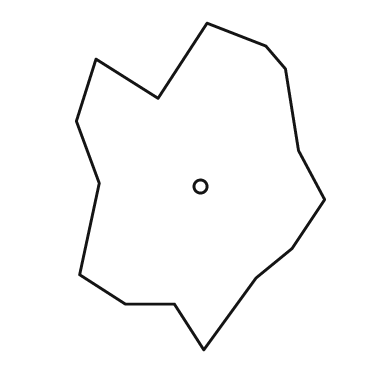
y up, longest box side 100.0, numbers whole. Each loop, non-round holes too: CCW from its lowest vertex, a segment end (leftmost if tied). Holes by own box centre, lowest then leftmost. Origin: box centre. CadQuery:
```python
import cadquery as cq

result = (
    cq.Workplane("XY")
    .moveTo(1.0, -50.0)
    .lineTo(17.0, -28.0)
    .lineTo(28.0, -19.0)
    .lineTo(38.0, -4.0)
    .lineTo(30.0, 11.0)
    .lineTo(26.0, 36.0)
    .lineTo(20.0, 43.0)
    .lineTo(2.0, 50.0)
    .lineTo(-13.0, 27.0)
    .lineTo(-32.0, 39.0)
    .lineTo(-38.0, 20.0)
    .lineTo(-31.0, 1.0)
    .lineTo(-37.0, -27.0)
    .lineTo(-23.0, -36.0)
    .lineTo(-8.0, -36.0)
    .close()
    .moveTo(0.0, 0.0)
    .circle(2.0)
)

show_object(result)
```